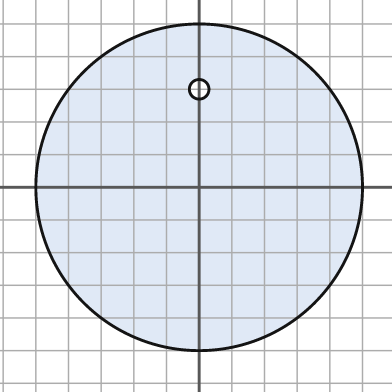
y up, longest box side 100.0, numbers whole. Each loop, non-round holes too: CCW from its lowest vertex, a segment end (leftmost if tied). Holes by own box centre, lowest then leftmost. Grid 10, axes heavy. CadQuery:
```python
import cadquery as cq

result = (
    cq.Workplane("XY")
    .moveTo(0.0, 0.0)
    .circle(50.0)
    .moveTo(0.0, 30.0)
    .circle(3.0)
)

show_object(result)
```